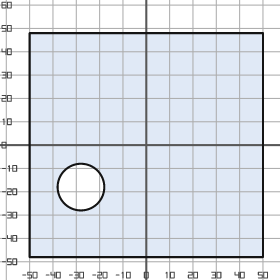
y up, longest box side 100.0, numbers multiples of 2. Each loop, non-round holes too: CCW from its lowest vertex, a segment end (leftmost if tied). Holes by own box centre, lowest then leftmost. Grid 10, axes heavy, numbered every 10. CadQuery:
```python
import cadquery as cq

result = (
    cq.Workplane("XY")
    .moveTo(-50.0, -48.0)
    .lineTo(50.0, -48.0)
    .lineTo(50.0, 48.0)
    .lineTo(-50.0, 48.0)
    .close()
    .moveTo(-28.0, -18.0)
    .circle(10.0)
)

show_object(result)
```